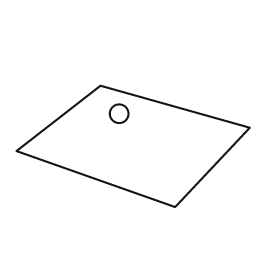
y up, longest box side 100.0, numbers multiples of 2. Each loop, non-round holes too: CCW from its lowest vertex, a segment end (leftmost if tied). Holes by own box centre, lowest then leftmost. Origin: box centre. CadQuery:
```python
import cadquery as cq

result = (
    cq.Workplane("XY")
    .moveTo(18.0, -26.0)
    .lineTo(50.0, 8.0)
    .lineTo(-14.0, 26.0)
    .lineTo(-50.0, -2.0)
    .close()
    .moveTo(-6.0, 14.0)
    .circle(4.0)
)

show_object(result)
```